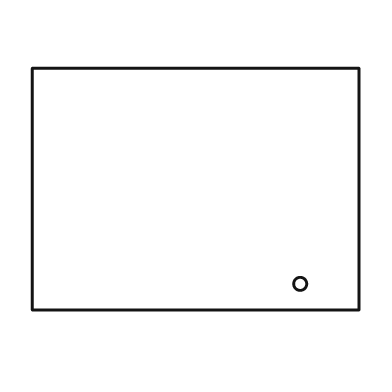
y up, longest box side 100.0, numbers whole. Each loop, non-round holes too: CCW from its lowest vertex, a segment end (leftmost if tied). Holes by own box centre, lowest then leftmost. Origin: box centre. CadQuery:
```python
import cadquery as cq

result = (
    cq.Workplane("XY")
    .moveTo(-50.0, -37.0)
    .lineTo(50.0, -37.0)
    .lineTo(50.0, 37.0)
    .lineTo(-50.0, 37.0)
    .close()
    .moveTo(32.0, -29.0)
    .circle(2.0)
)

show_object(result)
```